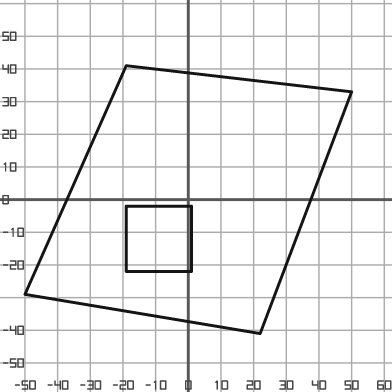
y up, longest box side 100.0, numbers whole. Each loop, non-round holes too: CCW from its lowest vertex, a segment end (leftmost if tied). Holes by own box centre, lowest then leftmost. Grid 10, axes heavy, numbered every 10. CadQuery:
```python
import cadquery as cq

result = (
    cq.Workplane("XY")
    .moveTo(22.0, -41.0)
    .lineTo(50.0, 33.0)
    .lineTo(-19.0, 41.0)
    .lineTo(-50.0, -29.0)
    .close()
    .moveTo(-19.0, -22.0)
    .lineTo(1.0, -22.0)
    .lineTo(1.0, -2.0)
    .lineTo(-19.0, -2.0)
    .close()
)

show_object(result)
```